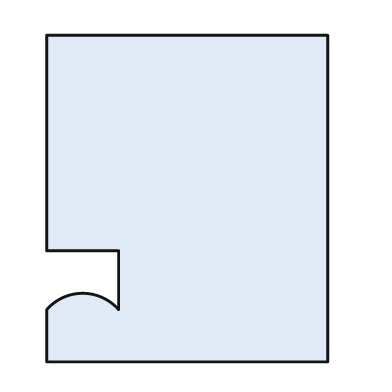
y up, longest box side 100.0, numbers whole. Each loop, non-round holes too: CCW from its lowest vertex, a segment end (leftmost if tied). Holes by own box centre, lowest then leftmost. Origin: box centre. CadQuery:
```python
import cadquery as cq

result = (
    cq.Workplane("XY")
    .moveTo(-43.0, -50.0)
    .lineTo(43.0, -50.0)
    .lineTo(43.0, 50.0)
    .lineTo(-43.0, 50.0)
    .lineTo(-43.0, -16.0)
    .lineTo(-21.0, -16.0)
    .lineTo(-21.0, -34.0)
    .threePointArc((-32.0, -29.0), (-43.0, -34.0))
    .close()
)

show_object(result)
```